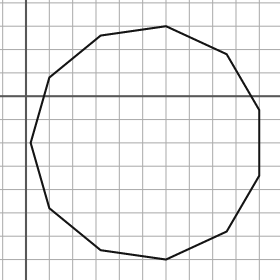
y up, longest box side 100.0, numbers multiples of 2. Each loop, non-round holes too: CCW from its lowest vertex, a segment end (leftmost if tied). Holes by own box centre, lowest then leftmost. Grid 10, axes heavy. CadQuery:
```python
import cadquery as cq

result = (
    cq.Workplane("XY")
    .moveTo(60.0, -70.0)
    .lineTo(86.0, -58.0)
    .lineTo(100.0, -34.0)
    .lineTo(100.0, -6.0)
    .lineTo(86.0, 18.0)
    .lineTo(60.0, 30.0)
    .lineTo(32.0, 26.0)
    .lineTo(10.0, 8.0)
    .lineTo(2.0, -20.0)
    .lineTo(10.0, -48.0)
    .lineTo(32.0, -66.0)
    .close()
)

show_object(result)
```